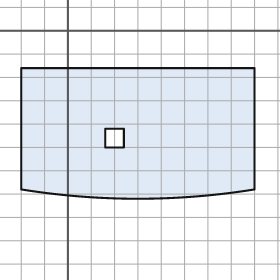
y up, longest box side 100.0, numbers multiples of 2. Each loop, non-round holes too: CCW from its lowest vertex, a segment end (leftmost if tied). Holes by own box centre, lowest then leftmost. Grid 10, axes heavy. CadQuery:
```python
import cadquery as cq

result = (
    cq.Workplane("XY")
    .moveTo(-20.0, -68.0)
    .threePointArc((30.0, -72.0), (80.0, -68.0))
    .lineTo(80.0, -16.0)
    .lineTo(-20.0, -16.0)
    .close()
    .moveTo(16.0, -50.0)
    .lineTo(24.0, -50.0)
    .lineTo(24.0, -42.0)
    .lineTo(16.0, -42.0)
    .close()
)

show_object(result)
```